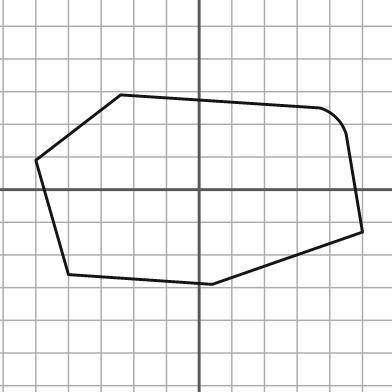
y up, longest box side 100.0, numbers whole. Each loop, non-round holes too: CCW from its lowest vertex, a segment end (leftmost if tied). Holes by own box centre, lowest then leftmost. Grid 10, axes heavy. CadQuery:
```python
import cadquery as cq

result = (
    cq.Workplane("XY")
    .moveTo(4.0, -29.0)
    .lineTo(50.0, -13.0)
    .lineTo(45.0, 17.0)
    .threePointArc((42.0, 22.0), (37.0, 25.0))
    .lineTo(-24.0, 29.0)
    .lineTo(-50.0, 9.0)
    .lineTo(-40.0, -26.0)
    .close()
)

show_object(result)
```